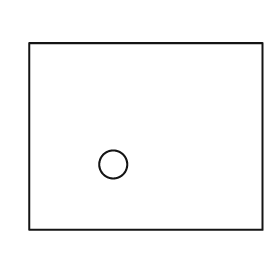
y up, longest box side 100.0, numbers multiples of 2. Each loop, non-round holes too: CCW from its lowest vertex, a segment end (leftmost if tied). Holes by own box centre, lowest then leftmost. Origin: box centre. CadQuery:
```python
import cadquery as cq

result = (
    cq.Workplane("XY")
    .moveTo(-50.0, -40.0)
    .lineTo(50.0, -40.0)
    .lineTo(50.0, 40.0)
    .lineTo(-50.0, 40.0)
    .close()
    .moveTo(-14.0, -12.0)
    .circle(6.0)
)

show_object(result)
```